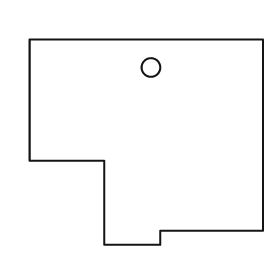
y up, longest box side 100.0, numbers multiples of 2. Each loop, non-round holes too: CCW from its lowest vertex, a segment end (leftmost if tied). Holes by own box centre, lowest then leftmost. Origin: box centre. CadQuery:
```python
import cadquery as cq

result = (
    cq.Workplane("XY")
    .moveTo(-18.0, -44.0)
    .lineTo(6.0, -44.0)
    .lineTo(6.0, -38.0)
    .lineTo(50.0, -38.0)
    .lineTo(50.0, 44.0)
    .lineTo(-50.0, 44.0)
    .lineTo(-50.0, -8.0)
    .lineTo(-18.0, -8.0)
    .close()
    .moveTo(2.0, 32.0)
    .circle(4.0)
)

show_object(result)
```